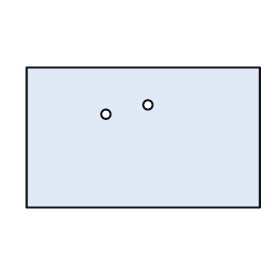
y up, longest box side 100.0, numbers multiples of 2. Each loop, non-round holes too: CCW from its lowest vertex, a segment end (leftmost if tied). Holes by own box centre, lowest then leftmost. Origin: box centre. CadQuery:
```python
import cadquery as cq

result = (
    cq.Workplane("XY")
    .moveTo(-50.0, -30.0)
    .lineTo(50.0, -30.0)
    .lineTo(50.0, 30.0)
    .lineTo(-50.0, 30.0)
    .close()
    .moveTo(-16.0, 10.0)
    .circle(2.0)
    .moveTo(2.0, 14.0)
    .circle(2.0)
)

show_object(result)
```